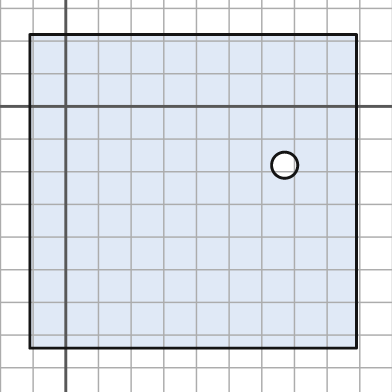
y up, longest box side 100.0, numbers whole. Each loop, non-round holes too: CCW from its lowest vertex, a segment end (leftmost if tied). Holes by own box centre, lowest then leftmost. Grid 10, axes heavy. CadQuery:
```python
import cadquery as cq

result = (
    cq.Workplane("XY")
    .moveTo(-11.0, -74.0)
    .lineTo(89.0, -74.0)
    .lineTo(89.0, 22.0)
    .lineTo(-11.0, 22.0)
    .close()
    .moveTo(67.0, -18.0)
    .circle(4.0)
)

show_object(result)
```